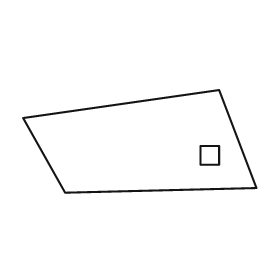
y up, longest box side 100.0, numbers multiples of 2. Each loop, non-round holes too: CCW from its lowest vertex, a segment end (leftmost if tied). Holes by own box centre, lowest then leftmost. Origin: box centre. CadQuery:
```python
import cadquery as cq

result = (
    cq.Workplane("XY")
    .moveTo(-32.0, -22.0)
    .lineTo(50.0, -20.0)
    .lineTo(34.0, 22.0)
    .lineTo(-50.0, 10.0)
    .close()
    .moveTo(26.0, -10.0)
    .lineTo(34.0, -10.0)
    .lineTo(34.0, -2.0)
    .lineTo(26.0, -2.0)
    .close()
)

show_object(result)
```